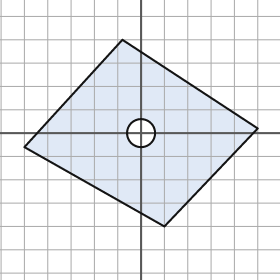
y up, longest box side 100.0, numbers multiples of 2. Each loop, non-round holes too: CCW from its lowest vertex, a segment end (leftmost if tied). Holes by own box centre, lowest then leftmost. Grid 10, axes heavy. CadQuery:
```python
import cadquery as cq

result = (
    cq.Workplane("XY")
    .moveTo(10.0, -40.0)
    .lineTo(50.0, 2.0)
    .lineTo(-8.0, 40.0)
    .lineTo(-50.0, -6.0)
    .close()
    .moveTo(0.0, 0.0)
    .circle(6.0)
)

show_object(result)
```